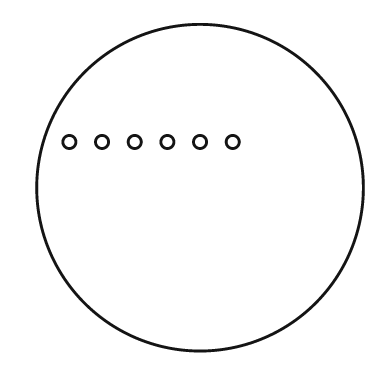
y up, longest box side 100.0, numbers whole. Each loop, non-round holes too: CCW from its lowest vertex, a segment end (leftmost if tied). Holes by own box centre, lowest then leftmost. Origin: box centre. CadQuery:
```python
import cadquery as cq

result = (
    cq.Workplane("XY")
    .moveTo(0.0, 0.0)
    .circle(50.0)
    .moveTo(-40.0, 14.0)
    .circle(2.0)
    .moveTo(-30.0, 14.0)
    .circle(2.0)
    .moveTo(-20.0, 14.0)
    .circle(2.0)
    .moveTo(-10.0, 14.0)
    .circle(2.0)
    .moveTo(0.0, 14.0)
    .circle(2.0)
    .moveTo(10.0, 14.0)
    .circle(2.0)
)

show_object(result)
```